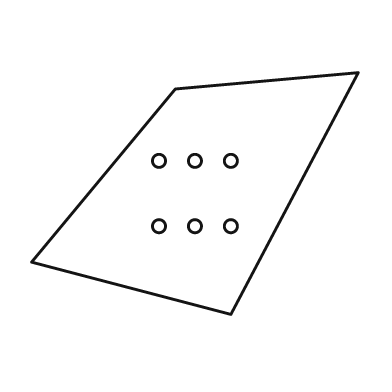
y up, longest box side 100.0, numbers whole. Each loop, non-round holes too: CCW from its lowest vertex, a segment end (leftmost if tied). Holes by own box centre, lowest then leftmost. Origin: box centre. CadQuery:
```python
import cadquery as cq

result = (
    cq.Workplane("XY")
    .moveTo(11.0, -37.0)
    .lineTo(50.0, 37.0)
    .lineTo(-6.0, 32.0)
    .lineTo(-50.0, -21.0)
    .close()
    .moveTo(-11.0, -10.0)
    .circle(2.0)
    .moveTo(0.0, -10.0)
    .circle(2.0)
    .moveTo(11.0, -10.0)
    .circle(2.0)
    .moveTo(-11.0, 10.0)
    .circle(2.0)
    .moveTo(0.0, 10.0)
    .circle(2.0)
    .moveTo(11.0, 10.0)
    .circle(2.0)
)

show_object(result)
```